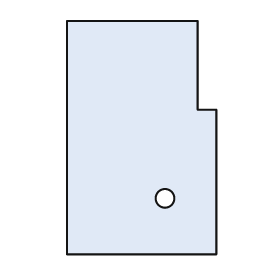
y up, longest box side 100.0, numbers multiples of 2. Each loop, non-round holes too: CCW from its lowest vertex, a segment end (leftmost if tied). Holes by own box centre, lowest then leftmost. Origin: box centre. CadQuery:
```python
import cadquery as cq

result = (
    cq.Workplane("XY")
    .moveTo(-32.0, -50.0)
    .lineTo(32.0, -50.0)
    .lineTo(32.0, 12.0)
    .lineTo(24.0, 12.0)
    .lineTo(24.0, 50.0)
    .lineTo(-32.0, 50.0)
    .close()
    .moveTo(10.0, -26.0)
    .circle(4.0)
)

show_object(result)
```